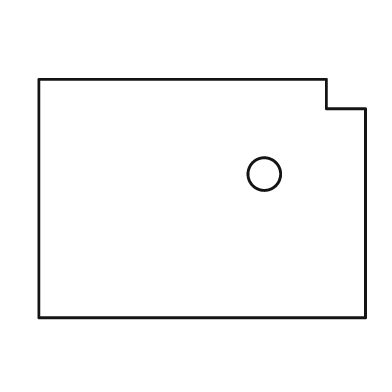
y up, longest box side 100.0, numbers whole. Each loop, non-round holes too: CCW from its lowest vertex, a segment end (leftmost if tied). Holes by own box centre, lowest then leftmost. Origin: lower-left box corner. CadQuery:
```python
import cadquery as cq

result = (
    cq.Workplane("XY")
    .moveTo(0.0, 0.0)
    .lineTo(100.0, 0.0)
    .lineTo(100.0, 64.0)
    .lineTo(88.0, 64.0)
    .lineTo(88.0, 73.0)
    .lineTo(0.0, 73.0)
    .close()
    .moveTo(69.0, 44.0)
    .circle(5.0)
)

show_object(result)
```